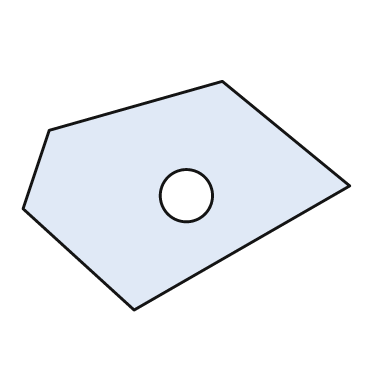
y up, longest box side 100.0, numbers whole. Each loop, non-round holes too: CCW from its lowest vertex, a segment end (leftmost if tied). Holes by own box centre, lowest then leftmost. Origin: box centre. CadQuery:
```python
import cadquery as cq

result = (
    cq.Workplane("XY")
    .moveTo(-16.0, -35.0)
    .lineTo(50.0, 3.0)
    .lineTo(11.0, 35.0)
    .lineTo(-42.0, 20.0)
    .lineTo(-50.0, -4.0)
    .close()
    .moveTo(0.0, 0.0)
    .circle(8.0)
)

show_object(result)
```